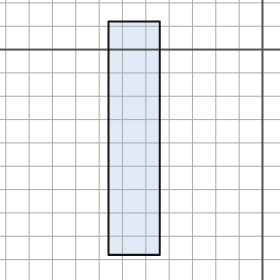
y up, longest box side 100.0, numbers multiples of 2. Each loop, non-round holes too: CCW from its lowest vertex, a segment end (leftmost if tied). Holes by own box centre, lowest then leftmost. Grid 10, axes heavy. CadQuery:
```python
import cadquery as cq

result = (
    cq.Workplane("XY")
    .moveTo(-66.0, -88.0)
    .lineTo(-44.0, -88.0)
    .lineTo(-44.0, 12.0)
    .lineTo(-66.0, 12.0)
    .close()
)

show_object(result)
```